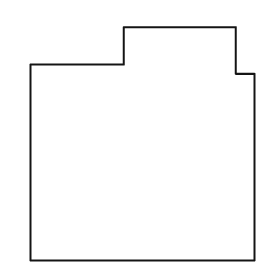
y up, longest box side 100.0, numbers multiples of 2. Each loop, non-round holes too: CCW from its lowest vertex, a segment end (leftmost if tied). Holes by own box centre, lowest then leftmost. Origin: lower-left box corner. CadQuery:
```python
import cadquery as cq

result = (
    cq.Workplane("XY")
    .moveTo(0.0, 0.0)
    .lineTo(96.0, 0.0)
    .lineTo(96.0, 80.0)
    .lineTo(88.0, 80.0)
    .lineTo(88.0, 100.0)
    .lineTo(40.0, 100.0)
    .lineTo(40.0, 84.0)
    .lineTo(0.0, 84.0)
    .close()
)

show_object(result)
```